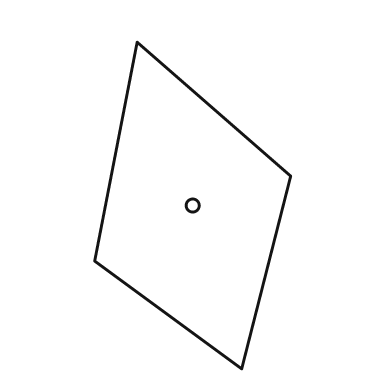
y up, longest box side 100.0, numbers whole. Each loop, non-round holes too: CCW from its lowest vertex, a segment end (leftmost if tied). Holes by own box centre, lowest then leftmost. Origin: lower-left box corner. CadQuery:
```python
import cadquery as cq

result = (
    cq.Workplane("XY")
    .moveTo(45.0, 0.0)
    .lineTo(60.0, 59.0)
    .lineTo(13.0, 100.0)
    .lineTo(0.0, 33.0)
    .close()
    .moveTo(30.0, 50.0)
    .circle(2.0)
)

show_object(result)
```